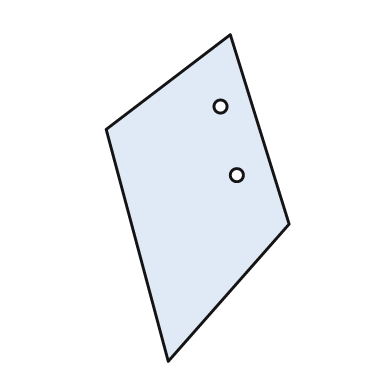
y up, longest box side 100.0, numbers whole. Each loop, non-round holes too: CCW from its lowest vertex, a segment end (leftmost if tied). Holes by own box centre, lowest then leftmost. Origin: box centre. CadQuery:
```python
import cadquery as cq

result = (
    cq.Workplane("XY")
    .moveTo(-9.0, -50.0)
    .lineTo(28.0, -8.0)
    .lineTo(10.0, 50.0)
    .lineTo(-28.0, 21.0)
    .close()
    .moveTo(12.0, 7.0)
    .circle(2.0)
    .moveTo(7.0, 28.0)
    .circle(2.0)
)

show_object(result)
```